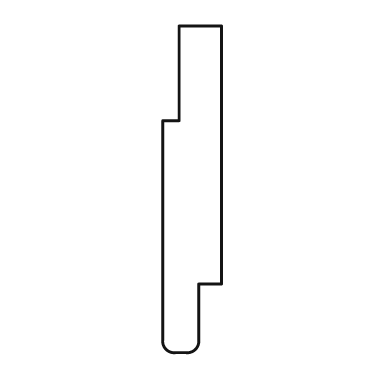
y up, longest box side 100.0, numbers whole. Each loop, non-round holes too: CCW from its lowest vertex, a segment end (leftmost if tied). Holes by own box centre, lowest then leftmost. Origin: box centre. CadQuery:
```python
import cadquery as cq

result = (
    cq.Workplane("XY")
    .moveTo(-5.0, -50.0)
    .lineTo(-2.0, -50.0)
    .threePointArc((1.0, -49.0), (2.0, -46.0))
    .lineTo(2.0, -29.0)
    .lineTo(9.0, -29.0)
    .lineTo(9.0, 50.0)
    .lineTo(-4.0, 50.0)
    .lineTo(-4.0, 21.0)
    .lineTo(-9.0, 21.0)
    .lineTo(-9.0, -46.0)
    .threePointArc((-8.0, -49.0), (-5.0, -50.0))
    .close()
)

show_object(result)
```